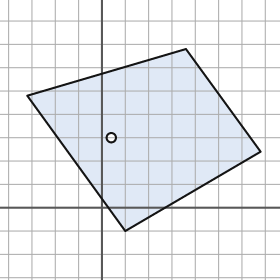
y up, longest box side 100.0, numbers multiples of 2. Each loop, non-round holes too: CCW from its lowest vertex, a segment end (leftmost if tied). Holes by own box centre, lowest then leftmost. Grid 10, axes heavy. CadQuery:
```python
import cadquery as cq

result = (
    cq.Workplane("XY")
    .moveTo(10.0, -10.0)
    .lineTo(68.0, 24.0)
    .lineTo(36.0, 68.0)
    .lineTo(-32.0, 48.0)
    .close()
    .moveTo(4.0, 30.0)
    .circle(2.0)
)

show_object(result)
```